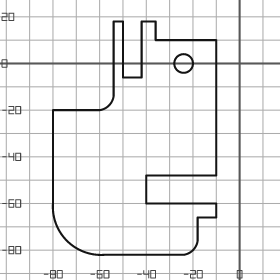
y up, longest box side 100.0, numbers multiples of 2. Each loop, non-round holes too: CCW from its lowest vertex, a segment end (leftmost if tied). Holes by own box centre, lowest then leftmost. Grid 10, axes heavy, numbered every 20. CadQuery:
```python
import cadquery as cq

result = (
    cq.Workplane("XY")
    .moveTo(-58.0, -82.0)
    .lineTo(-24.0, -82.0)
    .threePointArc((-20.0, -80.0), (-18.0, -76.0))
    .lineTo(-18.0, -66.0)
    .lineTo(-10.0, -66.0)
    .lineTo(-10.0, -60.0)
    .lineTo(-40.0, -60.0)
    .lineTo(-40.0, -48.0)
    .lineTo(-10.0, -48.0)
    .lineTo(-10.0, 10.0)
    .lineTo(-36.0, 10.0)
    .lineTo(-36.0, 18.0)
    .lineTo(-42.0, 18.0)
    .lineTo(-42.0, -6.0)
    .lineTo(-50.0, -6.0)
    .lineTo(-50.0, 18.0)
    .lineTo(-54.0, 18.0)
    .lineTo(-54.0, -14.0)
    .threePointArc((-56.0, -18.0), (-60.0, -20.0))
    .lineTo(-80.0, -20.0)
    .lineTo(-80.0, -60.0)
    .threePointArc((-74.0, -76.0), (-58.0, -82.0))
    .close()
    .moveTo(-24.0, 0.0)
    .circle(4.0)
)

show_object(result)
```